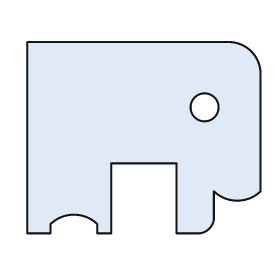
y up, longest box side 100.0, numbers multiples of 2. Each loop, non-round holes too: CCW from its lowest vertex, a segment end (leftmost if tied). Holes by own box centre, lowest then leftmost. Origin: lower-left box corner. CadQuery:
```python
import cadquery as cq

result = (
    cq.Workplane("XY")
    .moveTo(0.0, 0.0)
    .lineTo(10.0, 0.0)
    .lineTo(10.0, 4.0)
    .threePointArc((20.0, 8.0), (30.0, 4.0))
    .lineTo(30.0, 0.0)
    .lineTo(36.0, 0.0)
    .lineTo(36.0, 30.0)
    .lineTo(64.0, 30.0)
    .lineTo(64.0, 0.0)
    .lineTo(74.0, 0.0)
    .threePointArc((78.0, 2.0), (80.0, 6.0))
    .lineTo(80.0, 18.0)
    .threePointArc((90.0, 14.0), (100.0, 18.0))
    .lineTo(100.0, 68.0)
    .threePointArc((96.0, 78.0), (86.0, 82.0))
    .lineTo(0.0, 82.0)
    .close()
    .moveTo(76.0, 54.0)
    .circle(6.0)
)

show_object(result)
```